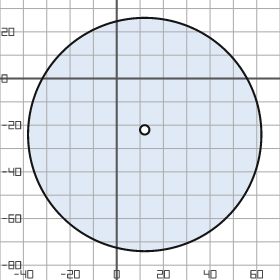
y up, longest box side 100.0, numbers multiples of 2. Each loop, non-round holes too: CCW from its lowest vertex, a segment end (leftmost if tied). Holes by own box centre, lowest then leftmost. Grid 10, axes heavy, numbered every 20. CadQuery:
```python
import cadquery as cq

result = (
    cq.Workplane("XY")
    .moveTo(12.0, -24.0)
    .circle(50.0)
    .moveTo(12.0, -22.0)
    .circle(2.0)
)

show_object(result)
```